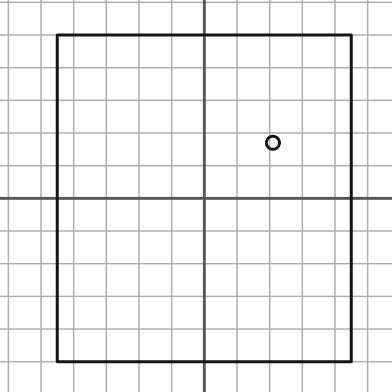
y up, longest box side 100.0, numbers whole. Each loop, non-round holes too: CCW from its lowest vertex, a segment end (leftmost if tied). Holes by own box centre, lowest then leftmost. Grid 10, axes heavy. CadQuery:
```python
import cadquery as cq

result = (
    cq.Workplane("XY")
    .moveTo(-45.0, -50.0)
    .lineTo(45.0, -50.0)
    .lineTo(45.0, 50.0)
    .lineTo(-45.0, 50.0)
    .close()
    .moveTo(21.0, 17.0)
    .circle(2.0)
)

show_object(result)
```